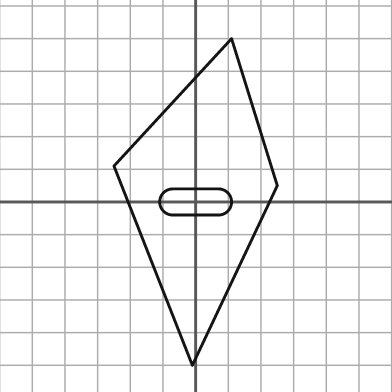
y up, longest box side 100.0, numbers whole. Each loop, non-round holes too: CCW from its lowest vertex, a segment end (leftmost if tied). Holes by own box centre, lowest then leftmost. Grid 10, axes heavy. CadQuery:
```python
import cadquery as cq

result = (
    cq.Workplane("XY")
    .moveTo(-1.0, -50.0)
    .lineTo(25.0, 5.0)
    .lineTo(11.0, 50.0)
    .lineTo(-25.0, 11.0)
    .close()
    .moveTo(-7.0, -4.0)
    .lineTo(7.0, -4.0)
    .threePointArc((11.0, 0.0), (7.0, 4.0))
    .lineTo(-7.0, 4.0)
    .threePointArc((-11.0, 0.0), (-7.0, -4.0))
    .close()
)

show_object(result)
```